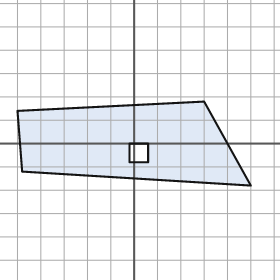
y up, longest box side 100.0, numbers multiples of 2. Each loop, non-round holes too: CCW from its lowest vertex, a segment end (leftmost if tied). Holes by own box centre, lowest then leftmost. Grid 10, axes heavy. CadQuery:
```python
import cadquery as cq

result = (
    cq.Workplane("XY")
    .moveTo(50.0, -18.0)
    .lineTo(30.0, 18.0)
    .lineTo(-50.0, 14.0)
    .lineTo(-48.0, -12.0)
    .close()
    .moveTo(-2.0, -8.0)
    .lineTo(6.0, -8.0)
    .lineTo(6.0, 0.0)
    .lineTo(-2.0, 0.0)
    .close()
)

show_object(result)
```